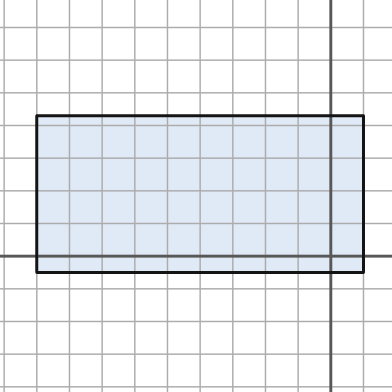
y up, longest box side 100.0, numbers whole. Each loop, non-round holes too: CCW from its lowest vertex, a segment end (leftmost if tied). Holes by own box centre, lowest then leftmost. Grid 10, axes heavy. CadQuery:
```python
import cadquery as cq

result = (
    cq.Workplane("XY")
    .moveTo(-90.0, -5.0)
    .lineTo(10.0, -5.0)
    .lineTo(10.0, 43.0)
    .lineTo(-90.0, 43.0)
    .close()
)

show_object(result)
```